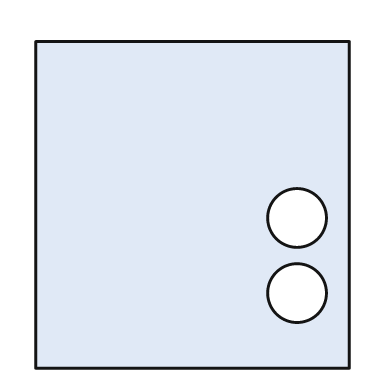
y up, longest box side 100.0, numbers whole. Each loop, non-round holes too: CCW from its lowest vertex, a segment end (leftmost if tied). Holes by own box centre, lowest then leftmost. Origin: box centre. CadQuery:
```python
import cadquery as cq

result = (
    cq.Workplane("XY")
    .moveTo(-48.0, -50.0)
    .lineTo(48.0, -50.0)
    .lineTo(48.0, 50.0)
    .lineTo(-48.0, 50.0)
    .close()
    .moveTo(32.0, -27.0)
    .circle(9.0)
    .moveTo(32.0, -4.0)
    .circle(9.0)
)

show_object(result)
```